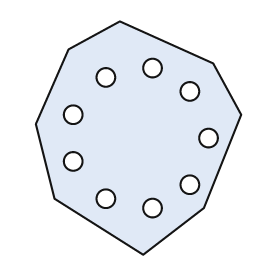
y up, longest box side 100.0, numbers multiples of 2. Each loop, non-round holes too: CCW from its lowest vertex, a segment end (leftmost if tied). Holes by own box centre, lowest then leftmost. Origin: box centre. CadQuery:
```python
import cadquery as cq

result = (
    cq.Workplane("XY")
    .moveTo(2.0, -50.0)
    .lineTo(28.0, -30.0)
    .lineTo(44.0, 10.0)
    .lineTo(32.0, 32.0)
    .lineTo(-8.0, 50.0)
    .lineTo(-30.0, 38.0)
    .lineTo(-44.0, 6.0)
    .lineTo(-36.0, -26.0)
    .close()
    .moveTo(6.0, -30.0)
    .circle(4.0)
    .moveTo(-14.0, -26.0)
    .circle(4.0)
    .moveTo(22.0, -20.0)
    .circle(4.0)
    .moveTo(-28.0, -10.0)
    .circle(4.0)
    .moveTo(30.0, 0.0)
    .circle(4.0)
    .moveTo(-28.0, 10.0)
    .circle(4.0)
    .moveTo(22.0, 20.0)
    .circle(4.0)
    .moveTo(-14.0, 26.0)
    .circle(4.0)
    .moveTo(6.0, 30.0)
    .circle(4.0)
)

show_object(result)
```